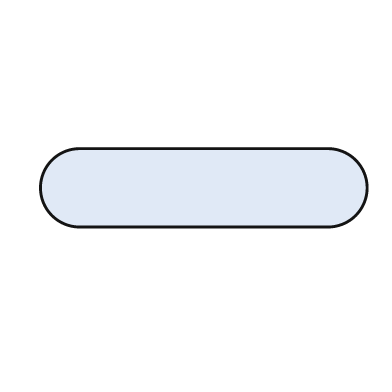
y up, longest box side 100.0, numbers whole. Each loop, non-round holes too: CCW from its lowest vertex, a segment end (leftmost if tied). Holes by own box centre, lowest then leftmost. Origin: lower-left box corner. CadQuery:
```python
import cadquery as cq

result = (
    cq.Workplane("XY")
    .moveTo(12.0, 0.0)
    .lineTo(88.0, 0.0)
    .threePointArc((100.0, 12.0), (88.0, 24.0))
    .lineTo(12.0, 24.0)
    .threePointArc((0.0, 12.0), (12.0, 0.0))
    .close()
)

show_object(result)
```